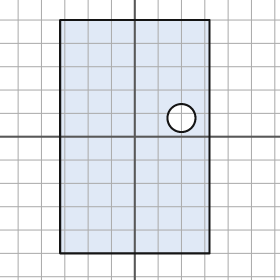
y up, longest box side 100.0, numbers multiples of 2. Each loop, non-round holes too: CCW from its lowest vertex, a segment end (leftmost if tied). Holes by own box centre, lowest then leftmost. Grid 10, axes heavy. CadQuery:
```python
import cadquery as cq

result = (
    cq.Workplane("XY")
    .moveTo(-32.0, -50.0)
    .lineTo(32.0, -50.0)
    .lineTo(32.0, 50.0)
    .lineTo(-32.0, 50.0)
    .close()
    .moveTo(20.0, 8.0)
    .circle(6.0)
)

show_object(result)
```